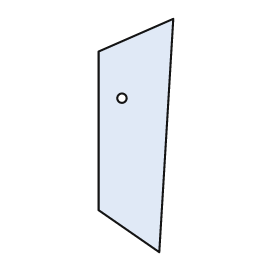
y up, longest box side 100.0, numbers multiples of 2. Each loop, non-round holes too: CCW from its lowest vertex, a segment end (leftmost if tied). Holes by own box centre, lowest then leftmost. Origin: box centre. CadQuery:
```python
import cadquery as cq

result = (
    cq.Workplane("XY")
    .moveTo(10.0, -50.0)
    .lineTo(16.0, 50.0)
    .lineTo(-16.0, 36.0)
    .lineTo(-16.0, -32.0)
    .close()
    .moveTo(-6.0, 16.0)
    .circle(2.0)
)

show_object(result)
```